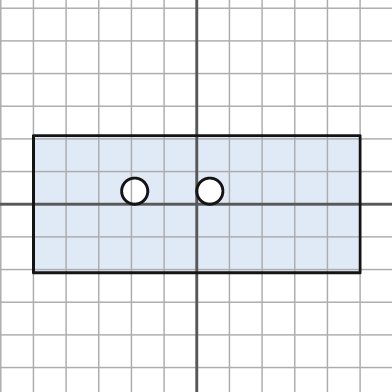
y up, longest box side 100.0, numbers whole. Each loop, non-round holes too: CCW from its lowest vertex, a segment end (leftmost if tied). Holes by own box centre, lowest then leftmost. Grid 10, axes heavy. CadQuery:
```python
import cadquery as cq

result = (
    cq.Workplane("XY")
    .moveTo(-50.0, -21.0)
    .lineTo(50.0, -21.0)
    .lineTo(50.0, 21.0)
    .lineTo(-50.0, 21.0)
    .close()
    .moveTo(-19.0, 4.0)
    .circle(4.0)
    .moveTo(4.0, 4.0)
    .circle(4.0)
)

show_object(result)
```